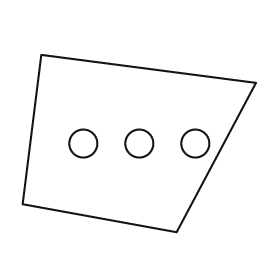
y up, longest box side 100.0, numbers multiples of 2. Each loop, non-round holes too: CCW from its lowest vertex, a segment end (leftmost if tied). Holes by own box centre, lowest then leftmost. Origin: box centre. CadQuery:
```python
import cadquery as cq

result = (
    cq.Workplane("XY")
    .moveTo(16.0, -38.0)
    .lineTo(50.0, 26.0)
    .lineTo(-42.0, 38.0)
    .lineTo(-50.0, -26.0)
    .close()
    .moveTo(-24.0, 0.0)
    .circle(6.0)
    .moveTo(0.0, 0.0)
    .circle(6.0)
    .moveTo(24.0, 0.0)
    .circle(6.0)
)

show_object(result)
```